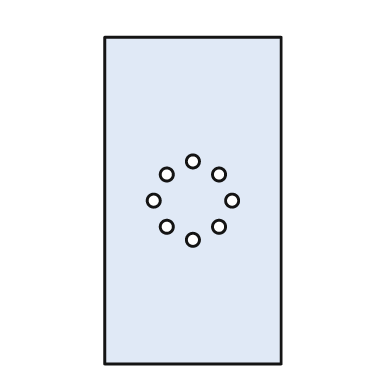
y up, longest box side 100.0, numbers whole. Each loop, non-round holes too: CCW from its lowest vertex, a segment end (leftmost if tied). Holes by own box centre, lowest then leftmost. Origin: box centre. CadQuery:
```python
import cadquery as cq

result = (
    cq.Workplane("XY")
    .moveTo(-27.0, -50.0)
    .lineTo(27.0, -50.0)
    .lineTo(27.0, 50.0)
    .lineTo(-27.0, 50.0)
    .close()
    .moveTo(0.0, -12.0)
    .circle(2.0)
    .moveTo(-8.0, -8.0)
    .circle(2.0)
    .moveTo(8.0, -8.0)
    .circle(2.0)
    .moveTo(-12.0, 0.0)
    .circle(2.0)
    .moveTo(12.0, 0.0)
    .circle(2.0)
    .moveTo(-8.0, 8.0)
    .circle(2.0)
    .moveTo(8.0, 8.0)
    .circle(2.0)
    .moveTo(0.0, 12.0)
    .circle(2.0)
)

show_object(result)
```